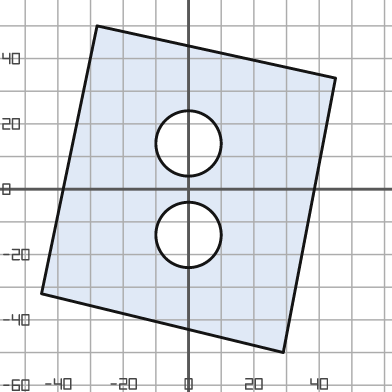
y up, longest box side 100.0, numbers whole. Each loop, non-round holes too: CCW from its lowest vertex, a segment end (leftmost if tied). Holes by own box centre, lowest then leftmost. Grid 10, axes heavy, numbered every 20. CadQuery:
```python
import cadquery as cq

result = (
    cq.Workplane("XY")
    .moveTo(29.0, -50.0)
    .lineTo(45.0, 34.0)
    .lineTo(-28.0, 50.0)
    .lineTo(-45.0, -32.0)
    .close()
    .moveTo(0.0, -14.0)
    .circle(10.0)
    .moveTo(0.0, 14.0)
    .circle(10.0)
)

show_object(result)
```